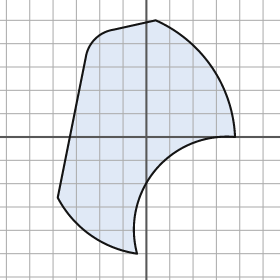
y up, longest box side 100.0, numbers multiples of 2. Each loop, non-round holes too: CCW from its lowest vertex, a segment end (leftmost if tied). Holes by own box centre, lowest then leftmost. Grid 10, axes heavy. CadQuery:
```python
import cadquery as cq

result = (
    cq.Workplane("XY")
    .moveTo(-4.0, -50.0)
    .threePointArc((4.0, -14.0), (38.0, 0.0))
    .threePointArc((28.0, 30.0), (4.0, 50.0))
    .lineTo(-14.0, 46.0)
    .threePointArc((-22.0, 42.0), (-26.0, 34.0))
    .lineTo(-38.0, -26.0)
    .threePointArc((-24.0, -42.0), (-4.0, -50.0))
    .close()
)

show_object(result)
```